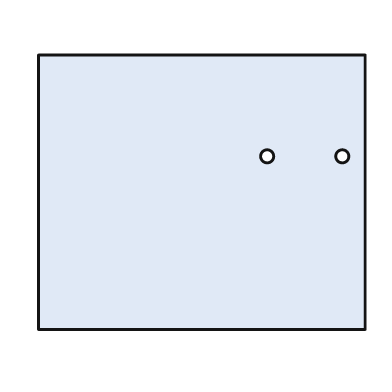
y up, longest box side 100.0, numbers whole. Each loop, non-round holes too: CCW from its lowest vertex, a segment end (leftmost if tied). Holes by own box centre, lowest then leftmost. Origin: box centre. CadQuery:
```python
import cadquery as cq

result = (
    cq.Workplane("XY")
    .moveTo(-50.0, -42.0)
    .lineTo(50.0, -42.0)
    .lineTo(50.0, 42.0)
    .lineTo(-50.0, 42.0)
    .close()
    .moveTo(20.0, 11.0)
    .circle(2.0)
    .moveTo(43.0, 11.0)
    .circle(2.0)
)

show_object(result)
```